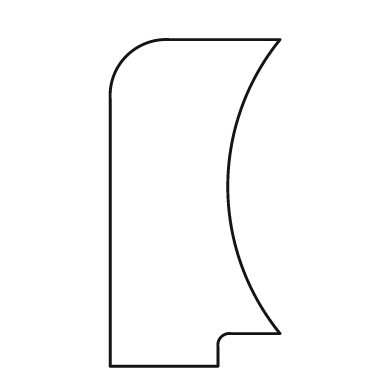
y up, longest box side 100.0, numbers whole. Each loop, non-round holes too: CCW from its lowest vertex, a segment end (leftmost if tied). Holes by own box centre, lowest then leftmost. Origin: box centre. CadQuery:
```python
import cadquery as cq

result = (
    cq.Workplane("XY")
    .moveTo(-26.0, -50.0)
    .lineTo(7.0, -50.0)
    .lineTo(7.0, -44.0)
    .threePointArc((8.0, -41.0), (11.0, -40.0))
    .lineTo(26.0, -40.0)
    .threePointArc((10.0, 5.0), (26.0, 50.0))
    .lineTo(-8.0, 50.0)
    .threePointArc((-21.0, 45.0), (-26.0, 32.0))
    .close()
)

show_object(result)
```